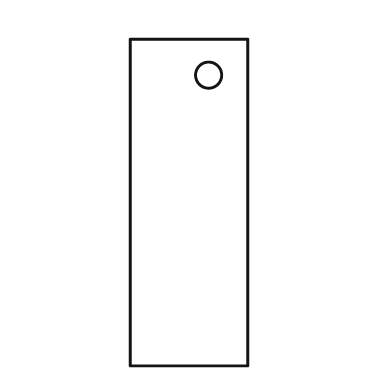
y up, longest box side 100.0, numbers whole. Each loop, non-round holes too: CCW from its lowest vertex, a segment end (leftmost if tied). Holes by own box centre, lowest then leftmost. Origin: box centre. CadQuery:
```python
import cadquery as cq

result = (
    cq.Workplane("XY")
    .moveTo(-18.0, -50.0)
    .lineTo(18.0, -50.0)
    .lineTo(18.0, 50.0)
    .lineTo(-18.0, 50.0)
    .close()
    .moveTo(6.0, 39.0)
    .circle(4.0)
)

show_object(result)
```